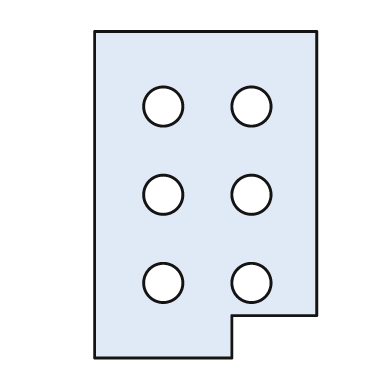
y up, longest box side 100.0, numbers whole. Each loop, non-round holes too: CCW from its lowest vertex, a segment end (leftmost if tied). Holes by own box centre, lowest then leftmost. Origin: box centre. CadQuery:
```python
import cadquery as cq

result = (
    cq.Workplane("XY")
    .moveTo(-34.0, -50.0)
    .lineTo(8.0, -50.0)
    .lineTo(8.0, -37.0)
    .lineTo(34.0, -37.0)
    .lineTo(34.0, 50.0)
    .lineTo(-34.0, 50.0)
    .close()
    .moveTo(-13.0, -27.0)
    .circle(6.0)
    .moveTo(14.0, -27.0)
    .circle(6.0)
    .moveTo(-13.0, 0.0)
    .circle(6.0)
    .moveTo(14.0, 0.0)
    .circle(6.0)
    .moveTo(-13.0, 27.0)
    .circle(6.0)
    .moveTo(14.0, 27.0)
    .circle(6.0)
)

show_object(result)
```